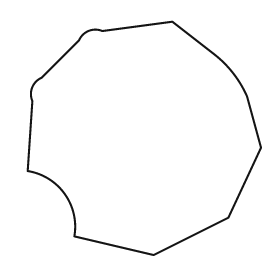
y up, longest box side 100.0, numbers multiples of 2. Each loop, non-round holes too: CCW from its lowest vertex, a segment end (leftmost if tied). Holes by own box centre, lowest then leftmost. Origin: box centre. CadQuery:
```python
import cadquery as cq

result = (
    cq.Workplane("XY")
    .moveTo(4.0, -50.0)
    .lineTo(36.0, -34.0)
    .lineTo(50.0, -4.0)
    .lineTo(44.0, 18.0)
    .threePointArc((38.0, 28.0), (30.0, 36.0))
    .lineTo(12.0, 50.0)
    .lineTo(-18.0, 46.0)
    .threePointArc((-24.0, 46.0), (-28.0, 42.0))
    .lineTo(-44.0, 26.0)
    .threePointArc((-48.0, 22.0), (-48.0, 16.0))
    .lineTo(-50.0, -14.0)
    .threePointArc((-34.0, -24.0), (-30.0, -42.0))
    .close()
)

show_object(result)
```